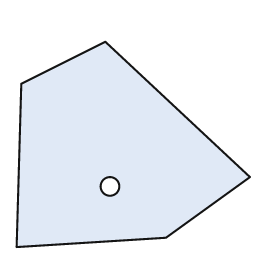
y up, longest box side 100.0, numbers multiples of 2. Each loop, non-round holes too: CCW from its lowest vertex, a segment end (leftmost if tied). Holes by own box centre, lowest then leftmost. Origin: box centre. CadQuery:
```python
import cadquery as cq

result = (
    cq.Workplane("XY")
    .moveTo(-50.0, -44.0)
    .lineTo(14.0, -40.0)
    .lineTo(50.0, -14.0)
    .lineTo(-12.0, 44.0)
    .lineTo(-48.0, 26.0)
    .close()
    .moveTo(-10.0, -18.0)
    .circle(4.0)
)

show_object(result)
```